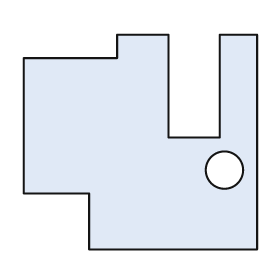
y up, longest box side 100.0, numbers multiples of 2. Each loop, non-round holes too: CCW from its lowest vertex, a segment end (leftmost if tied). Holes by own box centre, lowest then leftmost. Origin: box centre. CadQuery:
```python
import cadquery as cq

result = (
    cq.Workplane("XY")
    .moveTo(-22.0, -46.0)
    .lineTo(50.0, -46.0)
    .lineTo(50.0, 46.0)
    .lineTo(34.0, 46.0)
    .lineTo(34.0, 2.0)
    .lineTo(12.0, 2.0)
    .lineTo(12.0, 46.0)
    .lineTo(-10.0, 46.0)
    .lineTo(-10.0, 36.0)
    .lineTo(-50.0, 36.0)
    .lineTo(-50.0, -22.0)
    .lineTo(-22.0, -22.0)
    .close()
    .moveTo(36.0, -12.0)
    .circle(8.0)
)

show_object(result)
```